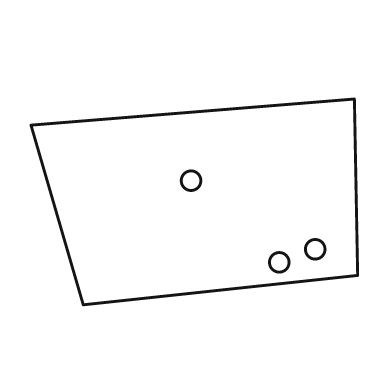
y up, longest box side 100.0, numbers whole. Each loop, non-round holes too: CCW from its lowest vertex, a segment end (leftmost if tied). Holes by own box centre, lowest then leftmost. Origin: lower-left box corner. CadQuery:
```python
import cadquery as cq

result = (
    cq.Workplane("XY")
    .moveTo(16.0, 0.0)
    .lineTo(100.0, 9.0)
    .lineTo(99.0, 63.0)
    .lineTo(0.0, 55.0)
    .close()
    .moveTo(76.0, 13.0)
    .circle(3.0)
    .moveTo(87.0, 17.0)
    .circle(3.0)
    .moveTo(49.0, 38.0)
    .circle(3.0)
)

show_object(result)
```